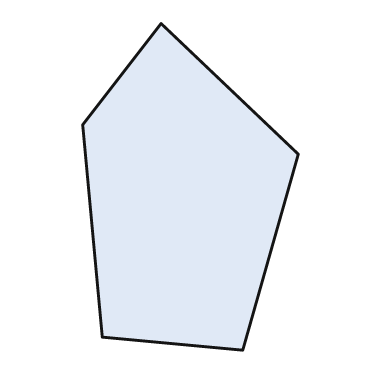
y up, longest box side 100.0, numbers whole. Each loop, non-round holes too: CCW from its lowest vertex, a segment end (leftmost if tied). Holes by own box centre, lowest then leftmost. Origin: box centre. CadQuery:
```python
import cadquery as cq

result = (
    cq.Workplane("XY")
    .moveTo(16.0, -50.0)
    .lineTo(33.0, 10.0)
    .lineTo(-9.0, 50.0)
    .lineTo(-33.0, 19.0)
    .lineTo(-27.0, -46.0)
    .close()
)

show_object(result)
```